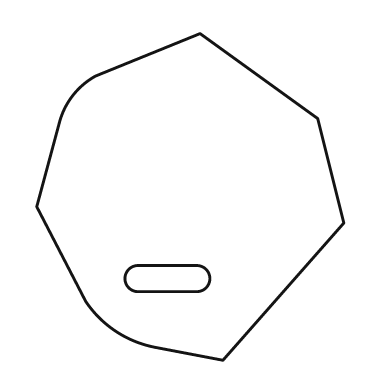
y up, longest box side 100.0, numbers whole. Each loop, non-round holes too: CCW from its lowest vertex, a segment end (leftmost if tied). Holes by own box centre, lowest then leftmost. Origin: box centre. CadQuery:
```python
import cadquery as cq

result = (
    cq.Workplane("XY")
    .moveTo(10.0, -50.0)
    .lineTo(47.0, -8.0)
    .lineTo(39.0, 24.0)
    .lineTo(3.0, 50.0)
    .lineTo(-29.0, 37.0)
    .threePointArc((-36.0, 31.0), (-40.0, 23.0))
    .lineTo(-47.0, -3.0)
    .lineTo(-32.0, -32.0)
    .threePointArc((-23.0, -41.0), (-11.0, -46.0))
    .close()
    .moveTo(-16.0, -29.0)
    .lineTo(2.0, -29.0)
    .threePointArc((6.0, -25.0), (2.0, -21.0))
    .lineTo(-16.0, -21.0)
    .threePointArc((-20.0, -25.0), (-16.0, -29.0))
    .close()
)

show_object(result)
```